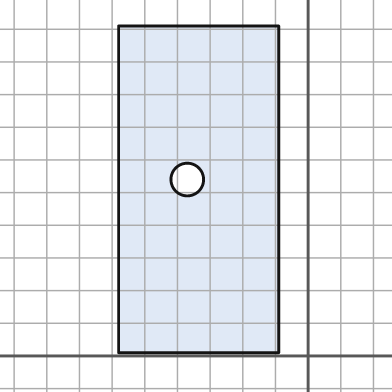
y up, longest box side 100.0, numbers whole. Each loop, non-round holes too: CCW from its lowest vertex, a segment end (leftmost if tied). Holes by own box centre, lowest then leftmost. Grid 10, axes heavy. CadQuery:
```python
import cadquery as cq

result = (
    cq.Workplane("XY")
    .moveTo(-58.0, 1.0)
    .lineTo(-9.0, 1.0)
    .lineTo(-9.0, 101.0)
    .lineTo(-58.0, 101.0)
    .close()
    .moveTo(-37.0, 54.0)
    .circle(5.0)
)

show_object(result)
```